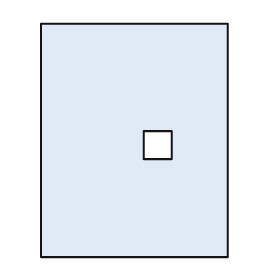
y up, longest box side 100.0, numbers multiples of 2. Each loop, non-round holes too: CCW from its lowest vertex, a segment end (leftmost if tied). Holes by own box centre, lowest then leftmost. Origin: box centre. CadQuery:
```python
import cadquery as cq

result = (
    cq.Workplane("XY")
    .moveTo(-40.0, -50.0)
    .lineTo(40.0, -50.0)
    .lineTo(40.0, 50.0)
    .lineTo(-40.0, 50.0)
    .close()
    .moveTo(4.0, -8.0)
    .lineTo(16.0, -8.0)
    .lineTo(16.0, 4.0)
    .lineTo(4.0, 4.0)
    .close()
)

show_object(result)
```